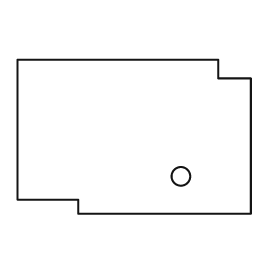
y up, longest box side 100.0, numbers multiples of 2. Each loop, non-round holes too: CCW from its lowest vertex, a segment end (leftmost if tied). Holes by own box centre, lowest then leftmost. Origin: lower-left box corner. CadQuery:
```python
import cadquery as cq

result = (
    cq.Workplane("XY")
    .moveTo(26.0, 0.0)
    .lineTo(100.0, 0.0)
    .lineTo(100.0, 58.0)
    .lineTo(86.0, 58.0)
    .lineTo(86.0, 66.0)
    .lineTo(0.0, 66.0)
    .lineTo(0.0, 6.0)
    .lineTo(26.0, 6.0)
    .close()
    .moveTo(70.0, 16.0)
    .circle(4.0)
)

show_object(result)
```